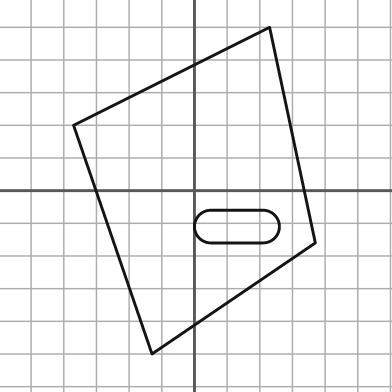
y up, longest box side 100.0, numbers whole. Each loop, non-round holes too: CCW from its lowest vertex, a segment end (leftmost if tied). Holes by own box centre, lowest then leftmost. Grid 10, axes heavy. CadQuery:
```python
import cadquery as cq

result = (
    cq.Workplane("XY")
    .moveTo(-13.0, -50.0)
    .lineTo(37.0, -16.0)
    .lineTo(23.0, 50.0)
    .lineTo(-37.0, 20.0)
    .close()
    .moveTo(5.0, -16.0)
    .lineTo(21.0, -16.0)
    .threePointArc((26.0, -11.0), (21.0, -6.0))
    .lineTo(5.0, -6.0)
    .threePointArc((0.0, -11.0), (5.0, -16.0))
    .close()
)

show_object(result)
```